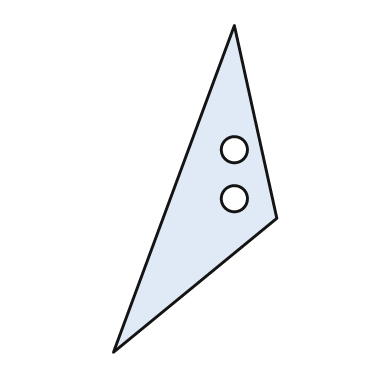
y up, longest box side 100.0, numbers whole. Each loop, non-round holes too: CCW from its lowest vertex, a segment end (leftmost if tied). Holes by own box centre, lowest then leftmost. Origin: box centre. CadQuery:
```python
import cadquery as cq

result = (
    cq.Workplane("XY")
    .moveTo(-25.0, -50.0)
    .lineTo(25.0, -9.0)
    .lineTo(12.0, 50.0)
    .close()
    .moveTo(12.0, -3.0)
    .circle(4.0)
    .moveTo(12.0, 12.0)
    .circle(4.0)
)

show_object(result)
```